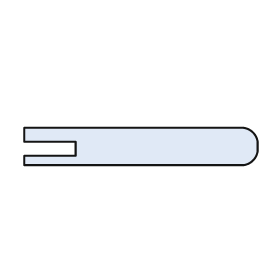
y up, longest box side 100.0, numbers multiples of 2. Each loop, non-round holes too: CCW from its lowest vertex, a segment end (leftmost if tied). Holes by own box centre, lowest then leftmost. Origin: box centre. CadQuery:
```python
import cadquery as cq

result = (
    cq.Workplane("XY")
    .moveTo(-50.0, -8.0)
    .lineTo(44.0, -8.0)
    .threePointArc((48.0, -6.0), (50.0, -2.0))
    .lineTo(50.0, 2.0)
    .threePointArc((48.0, 6.0), (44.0, 8.0))
    .lineTo(-50.0, 8.0)
    .lineTo(-50.0, 2.0)
    .lineTo(-28.0, 2.0)
    .lineTo(-28.0, -4.0)
    .lineTo(-50.0, -4.0)
    .close()
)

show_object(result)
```